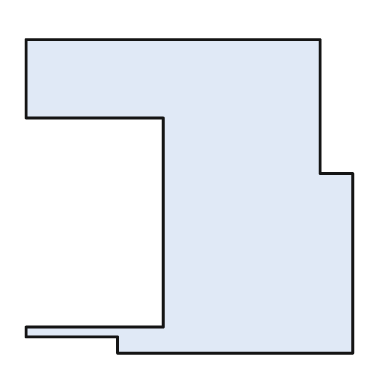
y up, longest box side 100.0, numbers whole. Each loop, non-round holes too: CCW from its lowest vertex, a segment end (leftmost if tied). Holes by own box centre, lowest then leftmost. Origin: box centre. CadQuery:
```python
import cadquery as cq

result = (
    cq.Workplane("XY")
    .moveTo(-22.0, -48.0)
    .lineTo(50.0, -48.0)
    .lineTo(50.0, 7.0)
    .lineTo(40.0, 7.0)
    .lineTo(40.0, 48.0)
    .lineTo(-50.0, 48.0)
    .lineTo(-50.0, 24.0)
    .lineTo(-8.0, 24.0)
    .lineTo(-8.0, -40.0)
    .lineTo(-50.0, -40.0)
    .lineTo(-50.0, -43.0)
    .lineTo(-22.0, -43.0)
    .close()
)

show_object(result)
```